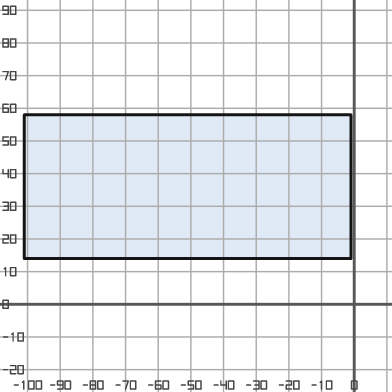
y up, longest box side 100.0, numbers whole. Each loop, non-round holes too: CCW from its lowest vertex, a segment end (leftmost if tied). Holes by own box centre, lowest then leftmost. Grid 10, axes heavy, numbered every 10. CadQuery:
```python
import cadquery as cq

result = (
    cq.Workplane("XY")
    .moveTo(-101.0, 14.0)
    .lineTo(-1.0, 14.0)
    .lineTo(-1.0, 58.0)
    .lineTo(-101.0, 58.0)
    .close()
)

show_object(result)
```